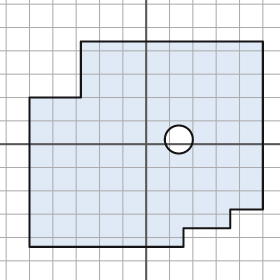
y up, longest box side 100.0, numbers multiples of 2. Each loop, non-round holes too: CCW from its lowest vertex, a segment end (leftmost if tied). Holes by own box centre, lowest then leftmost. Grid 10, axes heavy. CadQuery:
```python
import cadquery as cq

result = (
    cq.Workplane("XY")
    .moveTo(-50.0, -44.0)
    .lineTo(16.0, -44.0)
    .lineTo(16.0, -36.0)
    .lineTo(36.0, -36.0)
    .lineTo(36.0, -28.0)
    .lineTo(50.0, -28.0)
    .lineTo(50.0, 44.0)
    .lineTo(-28.0, 44.0)
    .lineTo(-28.0, 20.0)
    .lineTo(-50.0, 20.0)
    .close()
    .moveTo(14.0, 2.0)
    .circle(6.0)
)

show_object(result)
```